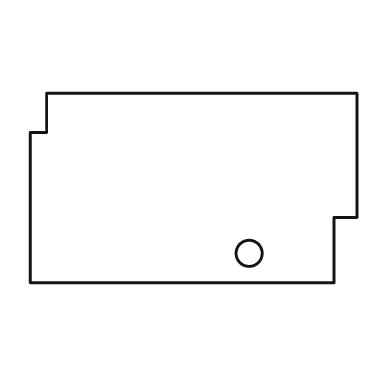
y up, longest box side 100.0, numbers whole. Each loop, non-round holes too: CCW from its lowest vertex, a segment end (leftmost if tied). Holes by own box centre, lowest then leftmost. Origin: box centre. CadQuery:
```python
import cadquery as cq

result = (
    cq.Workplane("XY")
    .moveTo(-50.0, -29.0)
    .lineTo(43.0, -29.0)
    .lineTo(43.0, -9.0)
    .lineTo(50.0, -9.0)
    .lineTo(50.0, 29.0)
    .lineTo(-45.0, 29.0)
    .lineTo(-45.0, 17.0)
    .lineTo(-50.0, 17.0)
    .close()
    .moveTo(17.0, -20.0)
    .circle(4.0)
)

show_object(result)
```